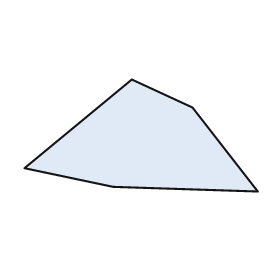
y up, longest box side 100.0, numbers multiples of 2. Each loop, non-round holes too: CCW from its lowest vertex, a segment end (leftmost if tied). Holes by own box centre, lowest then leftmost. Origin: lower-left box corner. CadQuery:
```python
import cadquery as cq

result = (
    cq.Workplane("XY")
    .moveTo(100.0, 0.0)
    .lineTo(72.0, 36.0)
    .lineTo(46.0, 48.0)
    .lineTo(0.0, 10.0)
    .lineTo(38.0, 2.0)
    .close()
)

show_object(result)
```